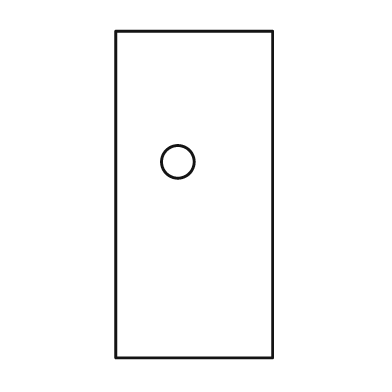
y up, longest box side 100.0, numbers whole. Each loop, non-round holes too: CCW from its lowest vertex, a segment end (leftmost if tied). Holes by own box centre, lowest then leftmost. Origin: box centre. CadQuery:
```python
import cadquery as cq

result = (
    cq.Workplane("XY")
    .moveTo(-24.0, -50.0)
    .lineTo(24.0, -50.0)
    .lineTo(24.0, 50.0)
    .lineTo(-24.0, 50.0)
    .close()
    .moveTo(-5.0, 10.0)
    .circle(5.0)
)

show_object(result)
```